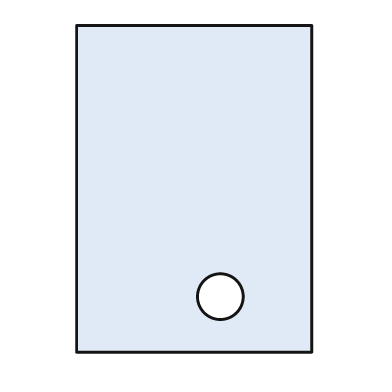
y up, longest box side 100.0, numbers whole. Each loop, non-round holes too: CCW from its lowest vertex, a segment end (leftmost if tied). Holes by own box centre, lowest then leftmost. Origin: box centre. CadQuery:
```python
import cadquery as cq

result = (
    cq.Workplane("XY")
    .moveTo(-36.0, -50.0)
    .lineTo(36.0, -50.0)
    .lineTo(36.0, 50.0)
    .lineTo(-36.0, 50.0)
    .close()
    .moveTo(8.0, -33.0)
    .circle(7.0)
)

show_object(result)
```